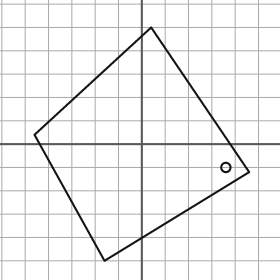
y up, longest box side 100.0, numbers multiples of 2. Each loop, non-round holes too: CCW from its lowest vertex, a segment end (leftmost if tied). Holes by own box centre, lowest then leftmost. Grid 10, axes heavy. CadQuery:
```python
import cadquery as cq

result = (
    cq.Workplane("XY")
    .moveTo(-16.0, -50.0)
    .lineTo(46.0, -12.0)
    .lineTo(4.0, 50.0)
    .lineTo(-46.0, 4.0)
    .close()
    .moveTo(36.0, -10.0)
    .circle(2.0)
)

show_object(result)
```